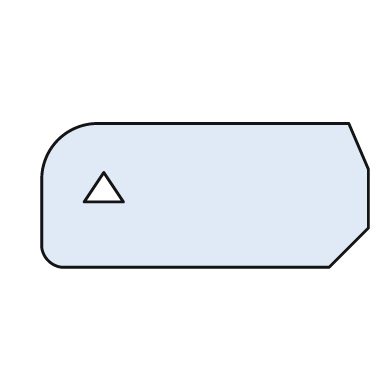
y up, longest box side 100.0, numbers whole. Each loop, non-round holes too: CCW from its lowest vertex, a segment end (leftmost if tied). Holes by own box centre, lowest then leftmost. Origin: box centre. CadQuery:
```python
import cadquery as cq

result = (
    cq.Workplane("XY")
    .moveTo(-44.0, -22.0)
    .lineTo(38.0, -22.0)
    .lineTo(50.0, -10.0)
    .lineTo(50.0, 8.0)
    .lineTo(44.0, 22.0)
    .lineTo(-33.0, 22.0)
    .threePointArc((-45.0, 17.0), (-50.0, 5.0))
    .lineTo(-50.0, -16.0)
    .threePointArc((-48.0, -20.0), (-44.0, -22.0))
    .close()
    .moveTo(-37.0, -2.0)
    .lineTo(-25.0, -2.0)
    .lineTo(-31.0, 7.0)
    .close()
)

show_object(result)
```